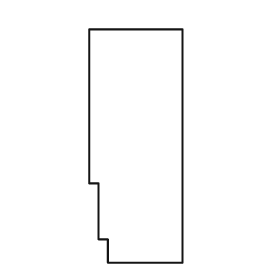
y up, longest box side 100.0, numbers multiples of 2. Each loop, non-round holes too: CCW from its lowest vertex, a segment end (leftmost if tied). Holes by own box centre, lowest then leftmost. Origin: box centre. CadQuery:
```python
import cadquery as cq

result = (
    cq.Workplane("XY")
    .moveTo(-12.0, -50.0)
    .lineTo(20.0, -50.0)
    .lineTo(20.0, 50.0)
    .lineTo(-20.0, 50.0)
    .lineTo(-20.0, -16.0)
    .lineTo(-16.0, -16.0)
    .lineTo(-16.0, -40.0)
    .lineTo(-12.0, -40.0)
    .close()
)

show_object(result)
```